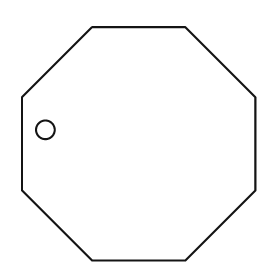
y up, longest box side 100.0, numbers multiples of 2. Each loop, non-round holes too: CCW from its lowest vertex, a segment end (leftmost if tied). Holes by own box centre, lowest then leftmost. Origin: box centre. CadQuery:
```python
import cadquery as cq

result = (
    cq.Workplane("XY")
    .moveTo(-20.0, -50.0)
    .lineTo(20.0, -50.0)
    .lineTo(50.0, -20.0)
    .lineTo(50.0, 20.0)
    .lineTo(20.0, 50.0)
    .lineTo(-20.0, 50.0)
    .lineTo(-50.0, 20.0)
    .lineTo(-50.0, -20.0)
    .close()
    .moveTo(-40.0, 6.0)
    .circle(4.0)
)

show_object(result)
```